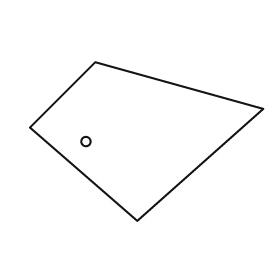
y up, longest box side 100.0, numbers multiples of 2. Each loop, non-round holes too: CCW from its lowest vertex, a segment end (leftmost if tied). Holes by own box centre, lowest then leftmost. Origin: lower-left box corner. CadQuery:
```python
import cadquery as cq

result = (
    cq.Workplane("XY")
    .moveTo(46.0, 0.0)
    .lineTo(100.0, 48.0)
    .lineTo(28.0, 68.0)
    .lineTo(0.0, 40.0)
    .close()
    .moveTo(24.0, 34.0)
    .circle(2.0)
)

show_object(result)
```